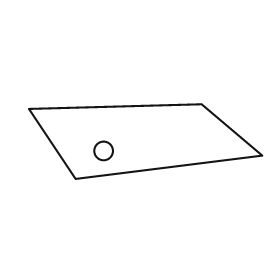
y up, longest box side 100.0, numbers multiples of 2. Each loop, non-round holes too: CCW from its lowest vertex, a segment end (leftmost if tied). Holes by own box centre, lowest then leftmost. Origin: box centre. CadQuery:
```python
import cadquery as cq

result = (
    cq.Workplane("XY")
    .moveTo(-30.0, -16.0)
    .lineTo(50.0, -6.0)
    .lineTo(24.0, 16.0)
    .lineTo(-50.0, 14.0)
    .close()
    .moveTo(-18.0, -4.0)
    .circle(4.0)
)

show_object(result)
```